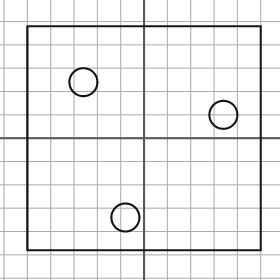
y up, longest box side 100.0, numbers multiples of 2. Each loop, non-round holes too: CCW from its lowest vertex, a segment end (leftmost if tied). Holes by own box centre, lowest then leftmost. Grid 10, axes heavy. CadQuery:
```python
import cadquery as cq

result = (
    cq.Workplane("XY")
    .moveTo(-50.0, -48.0)
    .lineTo(50.0, -48.0)
    .lineTo(50.0, 48.0)
    .lineTo(-50.0, 48.0)
    .close()
    .moveTo(-8.0, -34.0)
    .circle(6.0)
    .moveTo(34.0, 10.0)
    .circle(6.0)
    .moveTo(-26.0, 24.0)
    .circle(6.0)
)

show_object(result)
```